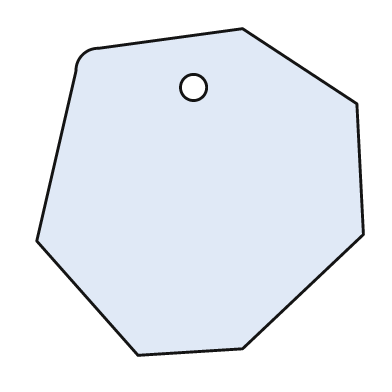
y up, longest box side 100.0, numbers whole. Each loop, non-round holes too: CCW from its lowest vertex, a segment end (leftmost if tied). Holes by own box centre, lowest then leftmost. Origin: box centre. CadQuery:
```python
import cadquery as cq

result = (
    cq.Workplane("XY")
    .moveTo(-19.0, -50.0)
    .lineTo(13.0, -48.0)
    .lineTo(50.0, -13.0)
    .lineTo(48.0, 27.0)
    .lineTo(13.0, 50.0)
    .lineTo(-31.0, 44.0)
    .threePointArc((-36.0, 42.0), (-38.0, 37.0))
    .lineTo(-50.0, -15.0)
    .close()
    .moveTo(-2.0, 32.0)
    .circle(4.0)
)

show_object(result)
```